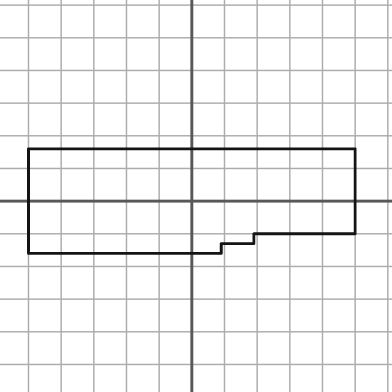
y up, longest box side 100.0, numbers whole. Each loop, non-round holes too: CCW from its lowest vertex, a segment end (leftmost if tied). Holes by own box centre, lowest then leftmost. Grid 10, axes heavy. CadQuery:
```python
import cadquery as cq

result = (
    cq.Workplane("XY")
    .moveTo(-50.0, -16.0)
    .lineTo(9.0, -16.0)
    .lineTo(9.0, -13.0)
    .lineTo(19.0, -13.0)
    .lineTo(19.0, -10.0)
    .lineTo(50.0, -10.0)
    .lineTo(50.0, 16.0)
    .lineTo(-50.0, 16.0)
    .close()
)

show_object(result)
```